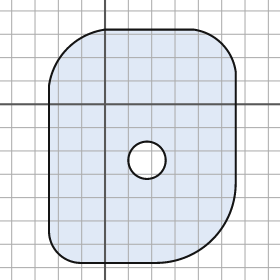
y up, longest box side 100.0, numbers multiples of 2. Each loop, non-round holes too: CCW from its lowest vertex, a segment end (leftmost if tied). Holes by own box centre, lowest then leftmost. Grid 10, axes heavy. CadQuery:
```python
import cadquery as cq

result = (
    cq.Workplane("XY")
    .moveTo(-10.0, -68.0)
    .lineTo(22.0, -68.0)
    .threePointArc((46.0, -58.0), (56.0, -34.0))
    .lineTo(56.0, 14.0)
    .threePointArc((50.0, 26.0), (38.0, 32.0))
    .lineTo(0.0, 32.0)
    .threePointArc((-16.0, 24.0), (-24.0, 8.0))
    .lineTo(-24.0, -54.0)
    .threePointArc((-20.0, -64.0), (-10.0, -68.0))
    .close()
    .moveTo(18.0, -24.0)
    .circle(8.0)
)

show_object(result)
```